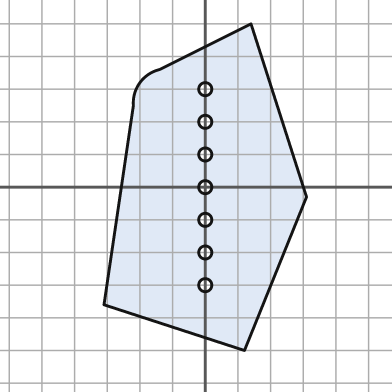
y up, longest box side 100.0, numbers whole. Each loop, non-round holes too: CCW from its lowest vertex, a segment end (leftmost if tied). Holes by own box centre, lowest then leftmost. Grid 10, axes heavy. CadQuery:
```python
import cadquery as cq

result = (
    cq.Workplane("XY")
    .moveTo(12.0, -50.0)
    .lineTo(31.0, -3.0)
    .lineTo(14.0, 50.0)
    .lineTo(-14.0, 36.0)
    .threePointArc((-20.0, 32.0), (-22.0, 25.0))
    .lineTo(-31.0, -36.0)
    .close()
    .moveTo(0.0, -30.0)
    .circle(2.0)
    .moveTo(0.0, -20.0)
    .circle(2.0)
    .moveTo(0.0, -10.0)
    .circle(2.0)
    .moveTo(0.0, 0.0)
    .circle(2.0)
    .moveTo(0.0, 10.0)
    .circle(2.0)
    .moveTo(0.0, 20.0)
    .circle(2.0)
    .moveTo(0.0, 30.0)
    .circle(2.0)
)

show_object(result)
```